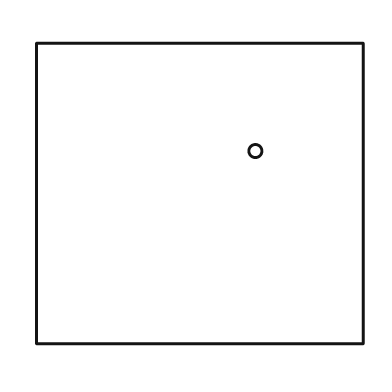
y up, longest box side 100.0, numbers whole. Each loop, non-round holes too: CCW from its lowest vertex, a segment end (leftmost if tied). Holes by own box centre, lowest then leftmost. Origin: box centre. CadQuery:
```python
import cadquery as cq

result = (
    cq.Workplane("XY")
    .moveTo(-50.0, -46.0)
    .lineTo(50.0, -46.0)
    .lineTo(50.0, 46.0)
    .lineTo(-50.0, 46.0)
    .close()
    .moveTo(17.0, 13.0)
    .circle(2.0)
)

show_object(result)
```